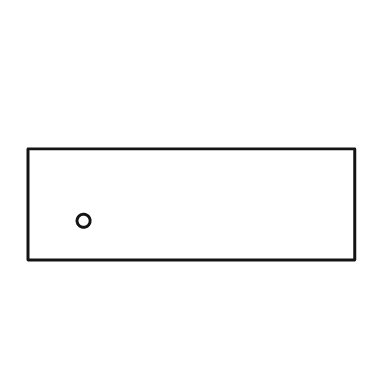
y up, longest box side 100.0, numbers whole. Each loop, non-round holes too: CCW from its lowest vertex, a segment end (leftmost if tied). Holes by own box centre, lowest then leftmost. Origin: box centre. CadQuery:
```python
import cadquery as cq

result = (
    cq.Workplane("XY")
    .moveTo(-50.0, -17.0)
    .lineTo(50.0, -17.0)
    .lineTo(50.0, 17.0)
    .lineTo(-50.0, 17.0)
    .close()
    .moveTo(-33.0, -5.0)
    .circle(2.0)
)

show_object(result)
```